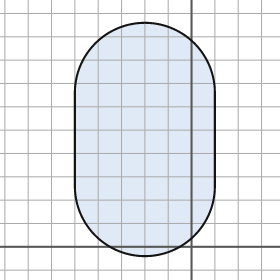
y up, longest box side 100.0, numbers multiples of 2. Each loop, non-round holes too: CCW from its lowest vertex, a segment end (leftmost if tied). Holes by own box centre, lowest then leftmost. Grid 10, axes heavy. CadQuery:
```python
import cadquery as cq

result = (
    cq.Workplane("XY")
    .moveTo(-50.0, 26.0)
    .threePointArc((-20.0, -4.0), (10.0, 26.0))
    .lineTo(10.0, 66.0)
    .threePointArc((-20.0, 96.0), (-50.0, 66.0))
    .close()
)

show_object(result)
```